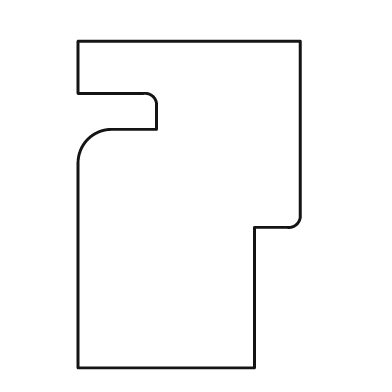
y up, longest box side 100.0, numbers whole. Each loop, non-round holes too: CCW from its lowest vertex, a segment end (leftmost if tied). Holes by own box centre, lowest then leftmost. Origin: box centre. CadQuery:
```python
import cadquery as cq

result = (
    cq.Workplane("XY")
    .moveTo(-34.0, -50.0)
    .lineTo(20.0, -50.0)
    .lineTo(20.0, -7.0)
    .lineTo(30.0, -7.0)
    .threePointArc((33.0, -6.0), (34.0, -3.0))
    .lineTo(34.0, 50.0)
    .lineTo(-34.0, 50.0)
    .lineTo(-34.0, 34.0)
    .lineTo(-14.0, 34.0)
    .threePointArc((-11.0, 33.0), (-10.0, 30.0))
    .lineTo(-10.0, 23.0)
    .lineTo(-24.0, 23.0)
    .threePointArc((-31.0, 20.0), (-34.0, 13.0))
    .close()
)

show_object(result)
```